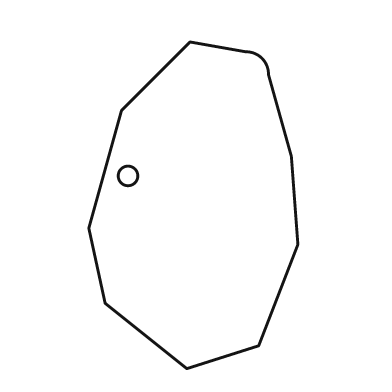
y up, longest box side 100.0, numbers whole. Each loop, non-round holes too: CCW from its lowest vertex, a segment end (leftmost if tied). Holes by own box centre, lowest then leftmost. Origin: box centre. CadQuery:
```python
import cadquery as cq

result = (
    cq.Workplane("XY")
    .moveTo(-2.0, -50.0)
    .lineTo(20.0, -43.0)
    .lineTo(32.0, -12.0)
    .lineTo(30.0, 15.0)
    .lineTo(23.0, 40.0)
    .threePointArc((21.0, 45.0), (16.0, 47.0))
    .lineTo(-1.0, 50.0)
    .lineTo(-22.0, 29.0)
    .lineTo(-32.0, -7.0)
    .lineTo(-27.0, -30.0)
    .close()
    .moveTo(-20.0, 9.0)
    .circle(3.0)
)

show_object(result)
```